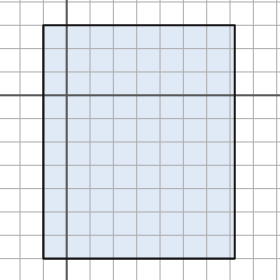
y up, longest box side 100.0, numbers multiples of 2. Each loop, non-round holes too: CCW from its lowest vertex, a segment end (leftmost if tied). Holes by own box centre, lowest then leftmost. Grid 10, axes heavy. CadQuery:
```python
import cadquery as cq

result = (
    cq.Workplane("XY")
    .moveTo(-10.0, -70.0)
    .lineTo(72.0, -70.0)
    .lineTo(72.0, 30.0)
    .lineTo(-10.0, 30.0)
    .close()
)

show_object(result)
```